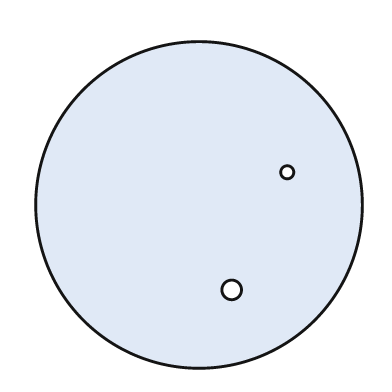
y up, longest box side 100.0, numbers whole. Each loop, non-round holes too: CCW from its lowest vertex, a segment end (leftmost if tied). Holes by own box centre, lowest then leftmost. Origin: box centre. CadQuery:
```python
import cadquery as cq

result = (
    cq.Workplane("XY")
    .moveTo(0.0, 0.0)
    .circle(50.0)
    .moveTo(10.0, -26.0)
    .circle(3.0)
    .moveTo(27.0, 10.0)
    .circle(2.0)
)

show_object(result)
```